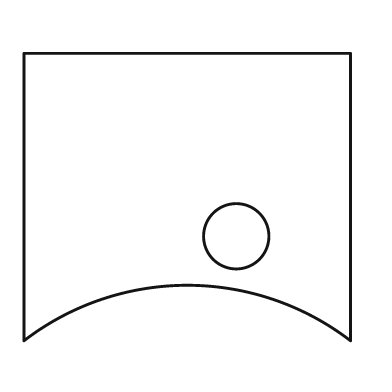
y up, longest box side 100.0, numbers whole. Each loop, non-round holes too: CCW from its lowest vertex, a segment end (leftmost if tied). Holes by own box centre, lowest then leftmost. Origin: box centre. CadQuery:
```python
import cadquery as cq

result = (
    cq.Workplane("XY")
    .moveTo(-50.0, -44.0)
    .threePointArc((0.0, -27.0), (50.0, -44.0))
    .lineTo(50.0, 44.0)
    .lineTo(-50.0, 44.0)
    .close()
    .moveTo(15.0, -12.0)
    .circle(10.0)
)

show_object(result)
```